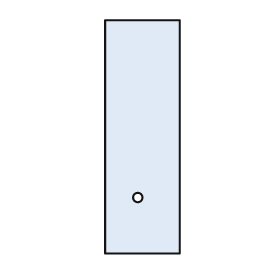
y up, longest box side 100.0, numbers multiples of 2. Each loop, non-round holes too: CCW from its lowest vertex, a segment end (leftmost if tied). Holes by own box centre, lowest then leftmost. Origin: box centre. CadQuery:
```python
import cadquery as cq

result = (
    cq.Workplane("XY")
    .moveTo(-16.0, -50.0)
    .lineTo(16.0, -50.0)
    .lineTo(16.0, 50.0)
    .lineTo(-16.0, 50.0)
    .close()
    .moveTo(-2.0, -26.0)
    .circle(2.0)
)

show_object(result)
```